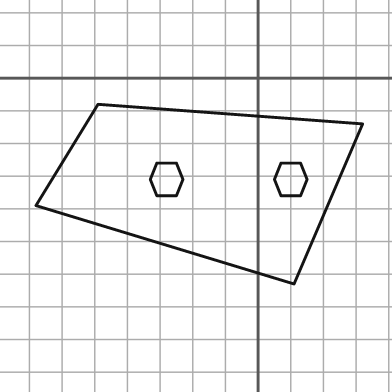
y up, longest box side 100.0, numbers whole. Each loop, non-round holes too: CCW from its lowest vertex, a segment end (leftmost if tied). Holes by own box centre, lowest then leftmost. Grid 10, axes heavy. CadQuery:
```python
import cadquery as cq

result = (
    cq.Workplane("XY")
    .moveTo(11.0, -63.0)
    .lineTo(32.0, -14.0)
    .lineTo(-49.0, -8.0)
    .lineTo(-68.0, -39.0)
    .close()
    .moveTo(-31.0, -36.0)
    .lineTo(-25.0, -36.0)
    .lineTo(-23.0, -31.0)
    .lineTo(-25.0, -26.0)
    .lineTo(-31.0, -26.0)
    .lineTo(-33.0, -31.0)
    .close()
    .moveTo(7.0, -36.0)
    .lineTo(13.0, -36.0)
    .lineTo(15.0, -31.0)
    .lineTo(13.0, -26.0)
    .lineTo(7.0, -26.0)
    .lineTo(5.0, -31.0)
    .close()
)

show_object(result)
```